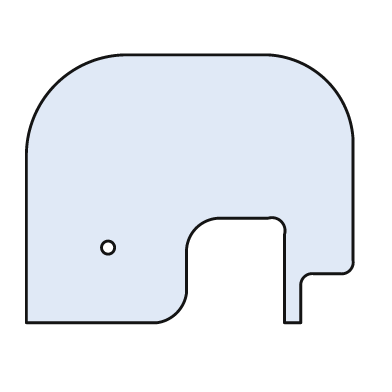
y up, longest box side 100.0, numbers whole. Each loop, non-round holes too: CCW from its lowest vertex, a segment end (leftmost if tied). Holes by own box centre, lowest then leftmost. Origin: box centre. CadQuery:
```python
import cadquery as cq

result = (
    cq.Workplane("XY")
    .moveTo(-50.0, -41.0)
    .lineTo(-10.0, -41.0)
    .threePointArc((-4.0, -38.0), (-1.0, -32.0))
    .lineTo(-1.0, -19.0)
    .threePointArc((2.0, -12.0), (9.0, -9.0))
    .lineTo(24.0, -9.0)
    .threePointArc((28.0, -10.0), (29.0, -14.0))
    .lineTo(29.0, -41.0)
    .lineTo(34.0, -41.0)
    .lineTo(34.0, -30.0)
    .threePointArc((35.0, -27.0), (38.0, -26.0))
    .lineTo(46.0, -26.0)
    .threePointArc((49.0, -25.0), (50.0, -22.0))
    .lineTo(50.0, 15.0)
    .threePointArc((42.0, 33.0), (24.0, 41.0))
    .lineTo(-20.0, 41.0)
    .threePointArc((-41.0, 32.0), (-50.0, 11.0))
    .close()
    .moveTo(-25.0, -18.0)
    .circle(2.0)
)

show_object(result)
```